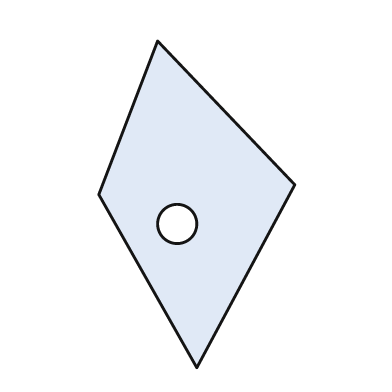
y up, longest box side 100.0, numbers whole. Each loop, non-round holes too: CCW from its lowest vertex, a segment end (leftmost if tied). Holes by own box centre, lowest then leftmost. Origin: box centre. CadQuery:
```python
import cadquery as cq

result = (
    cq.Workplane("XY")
    .moveTo(0.0, -50.0)
    .lineTo(30.0, 6.0)
    .lineTo(-12.0, 50.0)
    .lineTo(-30.0, 3.0)
    .close()
    .moveTo(-6.0, -6.0)
    .circle(6.0)
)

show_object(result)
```